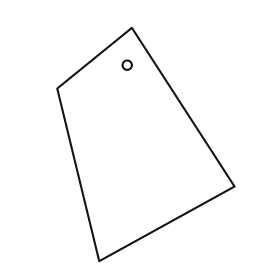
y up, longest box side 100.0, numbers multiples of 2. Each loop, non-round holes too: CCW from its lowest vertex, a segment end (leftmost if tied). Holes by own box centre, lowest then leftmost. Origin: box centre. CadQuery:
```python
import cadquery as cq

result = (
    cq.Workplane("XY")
    .moveTo(-20.0, -50.0)
    .lineTo(38.0, -18.0)
    .lineTo(-6.0, 50.0)
    .lineTo(-38.0, 24.0)
    .close()
    .moveTo(-8.0, 34.0)
    .circle(2.0)
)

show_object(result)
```